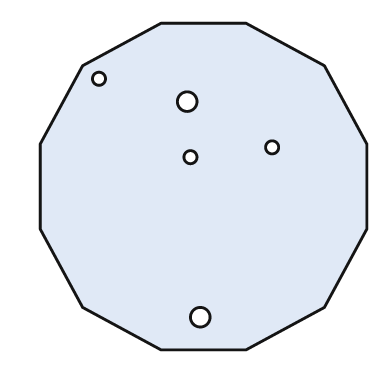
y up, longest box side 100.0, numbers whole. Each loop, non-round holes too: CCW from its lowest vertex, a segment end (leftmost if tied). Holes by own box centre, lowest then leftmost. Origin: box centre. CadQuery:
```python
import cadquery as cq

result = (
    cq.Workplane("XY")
    .moveTo(-13.0, -50.0)
    .lineTo(13.0, -50.0)
    .lineTo(37.0, -37.0)
    .lineTo(50.0, -13.0)
    .lineTo(50.0, 13.0)
    .lineTo(37.0, 37.0)
    .lineTo(13.0, 50.0)
    .lineTo(-13.0, 50.0)
    .lineTo(-37.0, 37.0)
    .lineTo(-50.0, 13.0)
    .lineTo(-50.0, -13.0)
    .lineTo(-37.0, -37.0)
    .close()
    .moveTo(-1.0, -40.0)
    .circle(3.0)
    .moveTo(-4.0, 9.0)
    .circle(2.0)
    .moveTo(21.0, 12.0)
    .circle(2.0)
    .moveTo(-5.0, 26.0)
    .circle(3.0)
    .moveTo(-32.0, 33.0)
    .circle(2.0)
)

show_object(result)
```